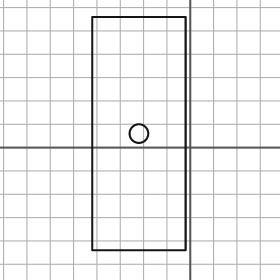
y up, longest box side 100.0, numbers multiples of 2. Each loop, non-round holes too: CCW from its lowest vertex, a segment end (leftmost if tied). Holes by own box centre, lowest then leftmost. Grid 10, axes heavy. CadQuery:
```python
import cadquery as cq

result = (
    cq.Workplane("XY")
    .moveTo(-42.0, -44.0)
    .lineTo(-2.0, -44.0)
    .lineTo(-2.0, 56.0)
    .lineTo(-42.0, 56.0)
    .close()
    .moveTo(-22.0, 6.0)
    .circle(4.0)
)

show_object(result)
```